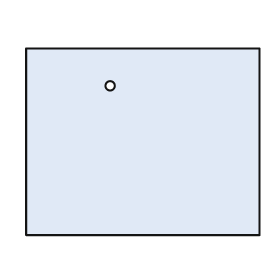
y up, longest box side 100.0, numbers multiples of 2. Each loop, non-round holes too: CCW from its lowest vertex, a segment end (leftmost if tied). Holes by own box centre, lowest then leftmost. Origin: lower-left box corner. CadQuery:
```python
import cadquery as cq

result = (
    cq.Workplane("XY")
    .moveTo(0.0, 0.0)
    .lineTo(100.0, 0.0)
    .lineTo(100.0, 80.0)
    .lineTo(0.0, 80.0)
    .close()
    .moveTo(36.0, 64.0)
    .circle(2.0)
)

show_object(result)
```